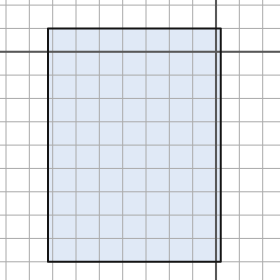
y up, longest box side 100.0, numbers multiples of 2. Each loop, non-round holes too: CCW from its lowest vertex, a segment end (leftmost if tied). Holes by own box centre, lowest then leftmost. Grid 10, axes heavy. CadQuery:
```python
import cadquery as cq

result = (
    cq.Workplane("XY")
    .moveTo(-72.0, -90.0)
    .lineTo(2.0, -90.0)
    .lineTo(2.0, 10.0)
    .lineTo(-72.0, 10.0)
    .close()
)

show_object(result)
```